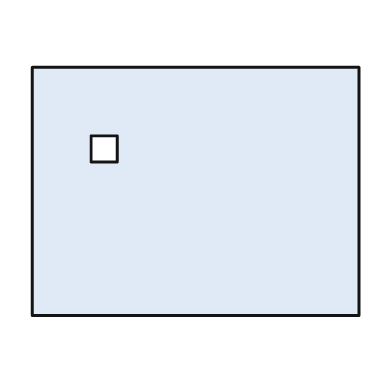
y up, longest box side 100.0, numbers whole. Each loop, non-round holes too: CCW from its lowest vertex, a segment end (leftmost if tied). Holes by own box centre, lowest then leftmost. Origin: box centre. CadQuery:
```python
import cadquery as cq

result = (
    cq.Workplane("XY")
    .moveTo(-50.0, -38.0)
    .lineTo(50.0, -38.0)
    .lineTo(50.0, 38.0)
    .lineTo(-50.0, 38.0)
    .close()
    .moveTo(-32.0, 9.0)
    .lineTo(-24.0, 9.0)
    .lineTo(-24.0, 17.0)
    .lineTo(-32.0, 17.0)
    .close()
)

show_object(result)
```